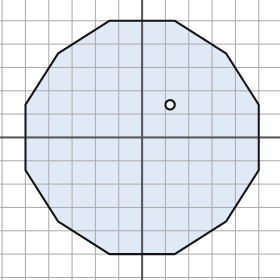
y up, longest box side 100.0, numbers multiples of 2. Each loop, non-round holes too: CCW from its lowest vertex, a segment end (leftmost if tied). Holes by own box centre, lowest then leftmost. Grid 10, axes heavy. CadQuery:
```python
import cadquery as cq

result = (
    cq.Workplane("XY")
    .moveTo(-14.0, -50.0)
    .lineTo(14.0, -50.0)
    .lineTo(36.0, -36.0)
    .lineTo(50.0, -14.0)
    .lineTo(50.0, 14.0)
    .lineTo(36.0, 36.0)
    .lineTo(14.0, 50.0)
    .lineTo(-14.0, 50.0)
    .lineTo(-36.0, 36.0)
    .lineTo(-50.0, 14.0)
    .lineTo(-50.0, -14.0)
    .lineTo(-36.0, -36.0)
    .close()
    .moveTo(12.0, 14.0)
    .circle(2.0)
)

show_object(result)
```